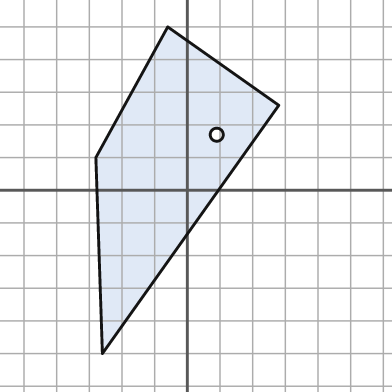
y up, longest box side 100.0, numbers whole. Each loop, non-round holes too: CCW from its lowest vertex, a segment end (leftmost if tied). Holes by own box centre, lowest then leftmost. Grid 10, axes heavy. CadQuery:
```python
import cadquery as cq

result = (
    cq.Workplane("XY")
    .moveTo(-26.0, -50.0)
    .lineTo(28.0, 26.0)
    .lineTo(-6.0, 50.0)
    .lineTo(-28.0, 10.0)
    .close()
    .moveTo(9.0, 17.0)
    .circle(2.0)
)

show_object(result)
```